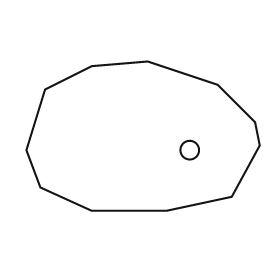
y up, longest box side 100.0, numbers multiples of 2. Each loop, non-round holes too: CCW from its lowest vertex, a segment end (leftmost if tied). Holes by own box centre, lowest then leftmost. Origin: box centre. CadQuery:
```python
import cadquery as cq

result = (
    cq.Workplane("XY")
    .moveTo(-22.0, -32.0)
    .lineTo(10.0, -32.0)
    .lineTo(38.0, -26.0)
    .lineTo(50.0, -4.0)
    .lineTo(48.0, 6.0)
    .lineTo(32.0, 22.0)
    .lineTo(2.0, 32.0)
    .lineTo(-22.0, 30.0)
    .lineTo(-42.0, 20.0)
    .lineTo(-50.0, -6.0)
    .lineTo(-44.0, -22.0)
    .close()
    .moveTo(20.0, -6.0)
    .circle(4.0)
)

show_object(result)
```